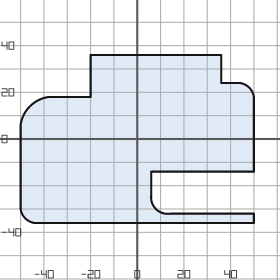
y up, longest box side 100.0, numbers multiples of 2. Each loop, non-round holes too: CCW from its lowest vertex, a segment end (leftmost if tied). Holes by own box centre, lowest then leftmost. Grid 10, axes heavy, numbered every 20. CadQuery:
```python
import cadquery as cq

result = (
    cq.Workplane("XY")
    .moveTo(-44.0, -36.0)
    .lineTo(50.0, -36.0)
    .lineTo(50.0, -32.0)
    .lineTo(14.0, -32.0)
    .threePointArc((8.0, -30.0), (6.0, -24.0))
    .lineTo(6.0, -14.0)
    .lineTo(50.0, -14.0)
    .lineTo(50.0, 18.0)
    .threePointArc((48.0, 22.0), (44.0, 24.0))
    .lineTo(36.0, 24.0)
    .lineTo(36.0, 36.0)
    .lineTo(-20.0, 36.0)
    .lineTo(-20.0, 18.0)
    .lineTo(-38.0, 18.0)
    .threePointArc((-46.0, 14.0), (-50.0, 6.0))
    .lineTo(-50.0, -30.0)
    .threePointArc((-48.0, -34.0), (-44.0, -36.0))
    .close()
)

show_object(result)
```